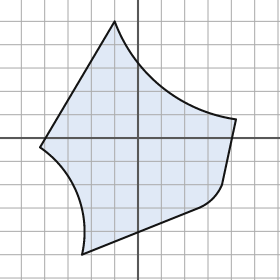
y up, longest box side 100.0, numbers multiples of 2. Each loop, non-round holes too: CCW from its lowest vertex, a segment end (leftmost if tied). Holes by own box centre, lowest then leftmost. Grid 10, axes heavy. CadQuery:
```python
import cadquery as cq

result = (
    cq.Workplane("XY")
    .moveTo(-24.0, -50.0)
    .lineTo(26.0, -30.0)
    .threePointArc((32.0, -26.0), (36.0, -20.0))
    .lineTo(42.0, 8.0)
    .threePointArc((10.0, 22.0), (-10.0, 50.0))
    .lineTo(-42.0, -4.0)
    .threePointArc((-26.0, -24.0), (-24.0, -50.0))
    .close()
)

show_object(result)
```